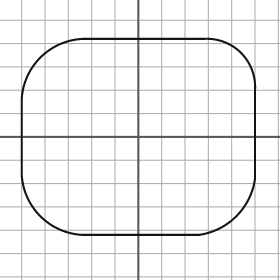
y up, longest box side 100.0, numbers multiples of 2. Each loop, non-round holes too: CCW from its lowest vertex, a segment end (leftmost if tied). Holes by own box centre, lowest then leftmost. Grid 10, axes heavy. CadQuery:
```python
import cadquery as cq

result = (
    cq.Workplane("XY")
    .moveTo(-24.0, -42.0)
    .lineTo(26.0, -42.0)
    .threePointArc((42.0, -34.0), (50.0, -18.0))
    .lineTo(50.0, 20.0)
    .threePointArc((44.0, 36.0), (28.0, 42.0))
    .lineTo(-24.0, 42.0)
    .threePointArc((-42.0, 34.0), (-50.0, 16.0))
    .lineTo(-50.0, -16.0)
    .threePointArc((-42.0, -34.0), (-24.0, -42.0))
    .close()
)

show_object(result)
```